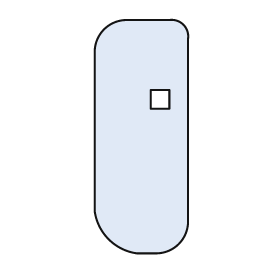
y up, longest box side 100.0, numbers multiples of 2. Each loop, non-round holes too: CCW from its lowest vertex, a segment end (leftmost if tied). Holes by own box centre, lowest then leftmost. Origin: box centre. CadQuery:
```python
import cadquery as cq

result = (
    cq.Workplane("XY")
    .moveTo(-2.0, -50.0)
    .lineTo(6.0, -50.0)
    .threePointArc((16.0, -46.0), (20.0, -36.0))
    .lineTo(20.0, 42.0)
    .threePointArc((18.0, 48.0), (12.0, 50.0))
    .lineTo(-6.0, 50.0)
    .threePointArc((-16.0, 46.0), (-20.0, 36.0))
    .lineTo(-20.0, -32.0)
    .threePointArc((-14.0, -44.0), (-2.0, -50.0))
    .close()
    .moveTo(4.0, 12.0)
    .lineTo(12.0, 12.0)
    .lineTo(12.0, 20.0)
    .lineTo(4.0, 20.0)
    .close()
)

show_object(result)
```